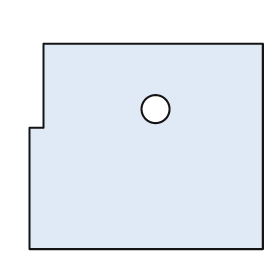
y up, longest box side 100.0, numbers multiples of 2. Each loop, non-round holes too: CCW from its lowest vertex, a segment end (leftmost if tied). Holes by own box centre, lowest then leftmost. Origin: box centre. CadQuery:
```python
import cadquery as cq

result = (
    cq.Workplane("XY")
    .moveTo(-50.0, -44.0)
    .lineTo(50.0, -44.0)
    .lineTo(50.0, 44.0)
    .lineTo(-44.0, 44.0)
    .lineTo(-44.0, 8.0)
    .lineTo(-50.0, 8.0)
    .close()
    .moveTo(4.0, 16.0)
    .circle(6.0)
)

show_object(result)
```